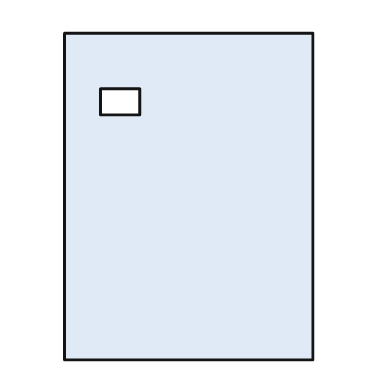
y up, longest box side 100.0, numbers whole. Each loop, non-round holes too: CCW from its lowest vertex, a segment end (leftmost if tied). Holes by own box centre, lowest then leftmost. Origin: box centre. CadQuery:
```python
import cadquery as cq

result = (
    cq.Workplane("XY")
    .moveTo(-38.0, -50.0)
    .lineTo(38.0, -50.0)
    .lineTo(38.0, 50.0)
    .lineTo(-38.0, 50.0)
    .close()
    .moveTo(-27.0, 25.0)
    .lineTo(-15.0, 25.0)
    .lineTo(-15.0, 33.0)
    .lineTo(-27.0, 33.0)
    .close()
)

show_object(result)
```